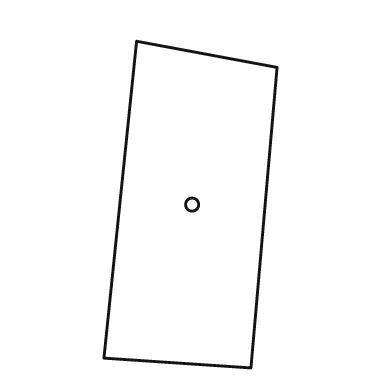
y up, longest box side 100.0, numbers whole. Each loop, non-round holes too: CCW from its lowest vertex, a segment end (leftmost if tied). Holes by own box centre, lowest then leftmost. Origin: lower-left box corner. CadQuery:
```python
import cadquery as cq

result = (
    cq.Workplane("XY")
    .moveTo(45.0, 0.0)
    .lineTo(53.0, 92.0)
    .lineTo(10.0, 100.0)
    .lineTo(0.0, 3.0)
    .close()
    .moveTo(27.0, 50.0)
    .circle(2.0)
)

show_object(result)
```